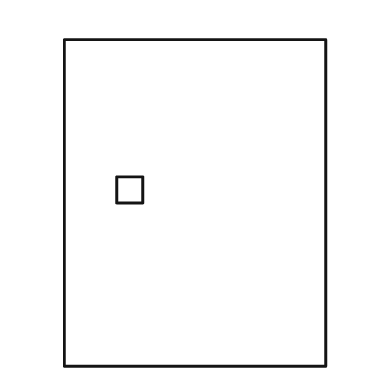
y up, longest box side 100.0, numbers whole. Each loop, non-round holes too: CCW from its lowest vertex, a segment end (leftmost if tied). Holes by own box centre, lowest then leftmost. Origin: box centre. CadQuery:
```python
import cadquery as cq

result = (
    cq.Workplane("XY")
    .moveTo(-40.0, -50.0)
    .lineTo(40.0, -50.0)
    .lineTo(40.0, 50.0)
    .lineTo(-40.0, 50.0)
    .close()
    .moveTo(-24.0, 0.0)
    .lineTo(-16.0, 0.0)
    .lineTo(-16.0, 8.0)
    .lineTo(-24.0, 8.0)
    .close()
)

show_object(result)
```